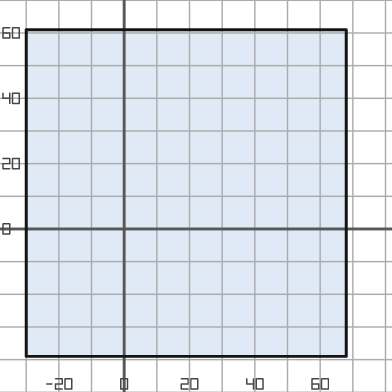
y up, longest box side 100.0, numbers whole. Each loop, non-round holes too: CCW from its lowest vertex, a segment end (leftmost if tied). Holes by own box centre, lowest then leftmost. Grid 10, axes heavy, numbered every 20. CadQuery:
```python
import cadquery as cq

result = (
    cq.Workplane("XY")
    .moveTo(-30.0, -39.0)
    .lineTo(68.0, -39.0)
    .lineTo(68.0, 61.0)
    .lineTo(-30.0, 61.0)
    .close()
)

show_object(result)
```